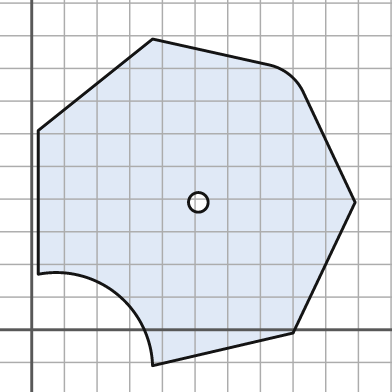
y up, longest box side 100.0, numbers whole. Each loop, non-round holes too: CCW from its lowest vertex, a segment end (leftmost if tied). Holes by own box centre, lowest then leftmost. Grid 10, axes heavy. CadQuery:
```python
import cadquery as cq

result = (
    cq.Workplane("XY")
    .moveTo(37.0, -11.0)
    .lineTo(80.0, -1.0)
    .lineTo(99.0, 39.0)
    .lineTo(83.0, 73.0)
    .threePointArc((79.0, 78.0), (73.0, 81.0))
    .lineTo(37.0, 89.0)
    .lineTo(2.0, 61.0)
    .lineTo(2.0, 17.0)
    .threePointArc((26.0, 11.0), (37.0, -11.0))
    .close()
    .moveTo(51.0, 39.0)
    .circle(3.0)
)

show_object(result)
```